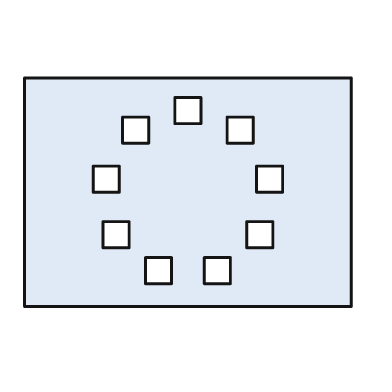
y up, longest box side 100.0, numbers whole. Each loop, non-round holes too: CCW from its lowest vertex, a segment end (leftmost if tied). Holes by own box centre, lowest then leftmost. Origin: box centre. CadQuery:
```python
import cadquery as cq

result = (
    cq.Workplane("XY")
    .moveTo(-50.0, -35.0)
    .lineTo(50.0, -35.0)
    .lineTo(50.0, 35.0)
    .lineTo(-50.0, 35.0)
    .close()
    .moveTo(-13.0, -28.0)
    .lineTo(-5.0, -28.0)
    .lineTo(-5.0, -20.0)
    .lineTo(-13.0, -20.0)
    .close()
    .moveTo(5.0, -28.0)
    .lineTo(13.0, -28.0)
    .lineTo(13.0, -20.0)
    .lineTo(5.0, -20.0)
    .close()
    .moveTo(-26.0, -17.0)
    .lineTo(-18.0, -17.0)
    .lineTo(-18.0, -9.0)
    .lineTo(-26.0, -9.0)
    .close()
    .moveTo(18.0, -17.0)
    .lineTo(26.0, -17.0)
    .lineTo(26.0, -9.0)
    .lineTo(18.0, -9.0)
    .close()
    .moveTo(-29.0, 0.0)
    .lineTo(-21.0, 0.0)
    .lineTo(-21.0, 8.0)
    .lineTo(-29.0, 8.0)
    .close()
    .moveTo(21.0, 0.0)
    .lineTo(29.0, 0.0)
    .lineTo(29.0, 8.0)
    .lineTo(21.0, 8.0)
    .close()
    .moveTo(-20.0, 15.0)
    .lineTo(-12.0, 15.0)
    .lineTo(-12.0, 23.0)
    .lineTo(-20.0, 23.0)
    .close()
    .moveTo(12.0, 15.0)
    .lineTo(20.0, 15.0)
    .lineTo(20.0, 23.0)
    .lineTo(12.0, 23.0)
    .close()
    .moveTo(-4.0, 21.0)
    .lineTo(4.0, 21.0)
    .lineTo(4.0, 29.0)
    .lineTo(-4.0, 29.0)
    .close()
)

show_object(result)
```